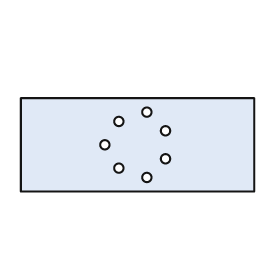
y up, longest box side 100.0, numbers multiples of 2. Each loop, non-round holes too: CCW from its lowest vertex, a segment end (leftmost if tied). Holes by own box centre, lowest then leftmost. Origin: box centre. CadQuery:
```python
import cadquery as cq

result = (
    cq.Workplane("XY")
    .moveTo(-50.0, -20.0)
    .lineTo(50.0, -20.0)
    .lineTo(50.0, 20.0)
    .lineTo(-50.0, 20.0)
    .close()
    .moveTo(4.0, -14.0)
    .circle(2.0)
    .moveTo(-8.0, -10.0)
    .circle(2.0)
    .moveTo(12.0, -6.0)
    .circle(2.0)
    .moveTo(-14.0, 0.0)
    .circle(2.0)
    .moveTo(12.0, 6.0)
    .circle(2.0)
    .moveTo(-8.0, 10.0)
    .circle(2.0)
    .moveTo(4.0, 14.0)
    .circle(2.0)
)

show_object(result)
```